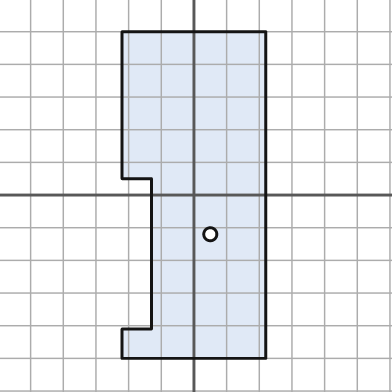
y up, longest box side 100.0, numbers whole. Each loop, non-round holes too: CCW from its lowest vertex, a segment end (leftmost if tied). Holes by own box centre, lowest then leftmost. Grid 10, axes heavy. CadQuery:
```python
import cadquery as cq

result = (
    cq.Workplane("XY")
    .moveTo(-22.0, -50.0)
    .lineTo(22.0, -50.0)
    .lineTo(22.0, 50.0)
    .lineTo(-22.0, 50.0)
    .lineTo(-22.0, 5.0)
    .lineTo(-13.0, 5.0)
    .lineTo(-13.0, -41.0)
    .lineTo(-22.0, -41.0)
    .close()
    .moveTo(5.0, -12.0)
    .circle(2.0)
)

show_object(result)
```